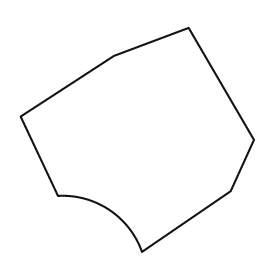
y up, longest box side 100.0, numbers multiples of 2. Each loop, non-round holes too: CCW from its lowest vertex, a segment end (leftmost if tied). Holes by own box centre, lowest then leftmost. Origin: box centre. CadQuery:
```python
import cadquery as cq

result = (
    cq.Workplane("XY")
    .moveTo(2.0, -48.0)
    .lineTo(40.0, -22.0)
    .lineTo(50.0, 0.0)
    .lineTo(22.0, 48.0)
    .lineTo(-10.0, 36.0)
    .lineTo(-50.0, 10.0)
    .lineTo(-34.0, -24.0)
    .threePointArc((-12.0, -30.0), (2.0, -48.0))
    .close()
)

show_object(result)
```